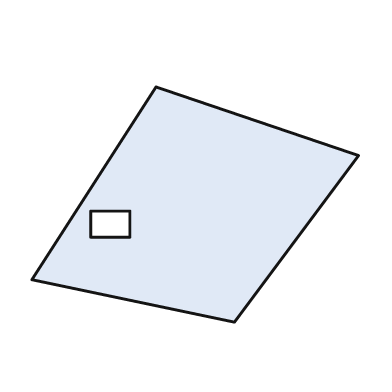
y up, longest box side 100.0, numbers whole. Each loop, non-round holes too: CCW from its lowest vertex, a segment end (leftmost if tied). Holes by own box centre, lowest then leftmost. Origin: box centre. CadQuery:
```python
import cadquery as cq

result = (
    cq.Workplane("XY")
    .moveTo(12.0, -36.0)
    .lineTo(50.0, 15.0)
    .lineTo(-12.0, 36.0)
    .lineTo(-50.0, -23.0)
    .close()
    .moveTo(-32.0, -10.0)
    .lineTo(-20.0, -10.0)
    .lineTo(-20.0, -2.0)
    .lineTo(-32.0, -2.0)
    .close()
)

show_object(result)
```